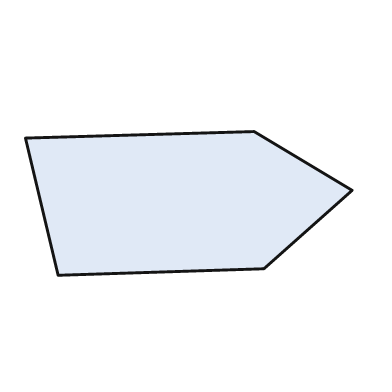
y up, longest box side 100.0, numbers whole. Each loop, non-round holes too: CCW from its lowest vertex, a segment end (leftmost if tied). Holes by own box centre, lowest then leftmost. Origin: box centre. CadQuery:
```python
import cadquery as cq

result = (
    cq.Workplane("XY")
    .moveTo(-40.0, -22.0)
    .lineTo(23.0, -20.0)
    .lineTo(50.0, 4.0)
    .lineTo(20.0, 22.0)
    .lineTo(-50.0, 20.0)
    .close()
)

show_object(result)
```